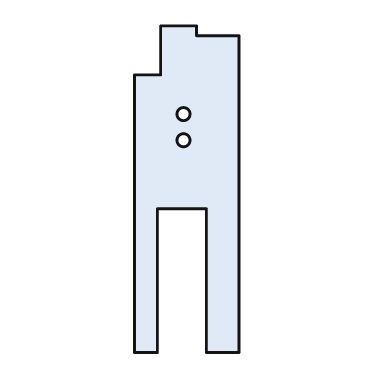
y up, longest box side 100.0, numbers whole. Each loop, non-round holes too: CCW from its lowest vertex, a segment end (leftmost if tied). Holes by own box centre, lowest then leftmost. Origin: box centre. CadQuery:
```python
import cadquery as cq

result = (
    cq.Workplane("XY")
    .moveTo(-16.0, -50.0)
    .lineTo(-9.0, -50.0)
    .lineTo(-9.0, -6.0)
    .lineTo(6.0, -6.0)
    .lineTo(6.0, -50.0)
    .lineTo(16.0, -50.0)
    .lineTo(16.0, 47.0)
    .lineTo(3.0, 47.0)
    .lineTo(3.0, 50.0)
    .lineTo(-8.0, 50.0)
    .lineTo(-8.0, 35.0)
    .lineTo(-16.0, 35.0)
    .close()
    .moveTo(-1.0, 15.0)
    .circle(2.0)
    .moveTo(-1.0, 23.0)
    .circle(2.0)
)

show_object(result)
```